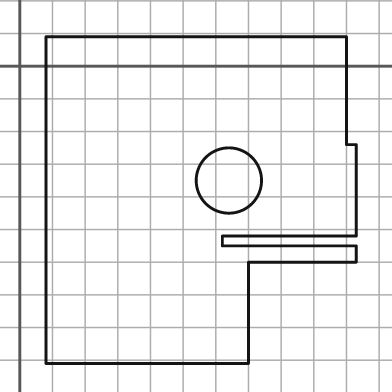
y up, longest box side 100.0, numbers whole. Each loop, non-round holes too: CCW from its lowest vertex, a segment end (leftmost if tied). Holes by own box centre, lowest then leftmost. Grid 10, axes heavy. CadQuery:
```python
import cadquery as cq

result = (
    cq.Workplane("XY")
    .moveTo(8.0, -91.0)
    .lineTo(70.0, -91.0)
    .lineTo(70.0, -60.0)
    .lineTo(103.0, -60.0)
    .lineTo(103.0, -55.0)
    .lineTo(62.0, -55.0)
    .lineTo(62.0, -52.0)
    .lineTo(103.0, -52.0)
    .lineTo(103.0, -24.0)
    .lineTo(100.0, -24.0)
    .lineTo(100.0, 9.0)
    .lineTo(8.0, 9.0)
    .close()
    .moveTo(64.0, -35.0)
    .circle(10.0)
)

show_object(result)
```